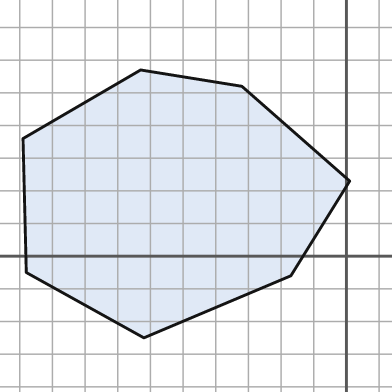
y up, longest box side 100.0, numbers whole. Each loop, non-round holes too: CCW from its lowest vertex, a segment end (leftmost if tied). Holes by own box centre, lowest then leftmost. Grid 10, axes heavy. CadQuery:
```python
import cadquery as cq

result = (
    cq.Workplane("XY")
    .moveTo(-62.0, -25.0)
    .lineTo(-17.0, -6.0)
    .lineTo(1.0, 23.0)
    .lineTo(-32.0, 52.0)
    .lineTo(-63.0, 57.0)
    .lineTo(-99.0, 36.0)
    .lineTo(-98.0, -5.0)
    .close()
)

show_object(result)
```